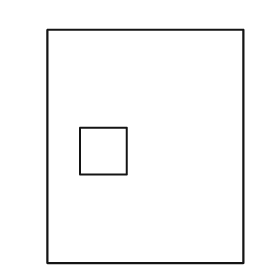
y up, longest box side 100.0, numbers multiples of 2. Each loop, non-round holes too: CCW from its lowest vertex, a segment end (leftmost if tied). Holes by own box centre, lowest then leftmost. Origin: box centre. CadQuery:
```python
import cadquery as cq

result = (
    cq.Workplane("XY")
    .moveTo(-42.0, -50.0)
    .lineTo(42.0, -50.0)
    .lineTo(42.0, 50.0)
    .lineTo(-42.0, 50.0)
    .close()
    .moveTo(-28.0, -12.0)
    .lineTo(-8.0, -12.0)
    .lineTo(-8.0, 8.0)
    .lineTo(-28.0, 8.0)
    .close()
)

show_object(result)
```